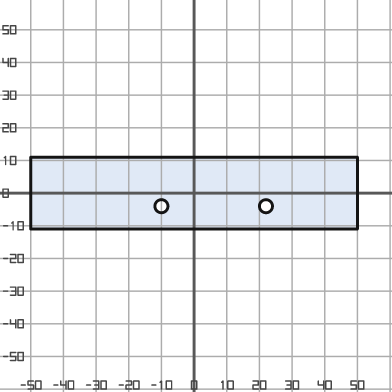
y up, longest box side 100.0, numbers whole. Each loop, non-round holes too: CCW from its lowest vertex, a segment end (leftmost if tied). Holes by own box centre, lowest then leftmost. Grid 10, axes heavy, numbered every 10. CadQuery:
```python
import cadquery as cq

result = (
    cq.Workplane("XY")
    .moveTo(-50.0, -11.0)
    .lineTo(50.0, -11.0)
    .lineTo(50.0, 11.0)
    .lineTo(-50.0, 11.0)
    .close()
    .moveTo(-10.0, -4.0)
    .circle(2.0)
    .moveTo(22.0, -4.0)
    .circle(2.0)
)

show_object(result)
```